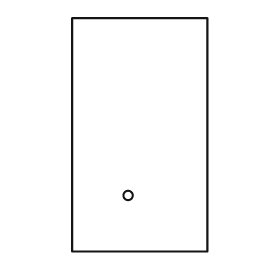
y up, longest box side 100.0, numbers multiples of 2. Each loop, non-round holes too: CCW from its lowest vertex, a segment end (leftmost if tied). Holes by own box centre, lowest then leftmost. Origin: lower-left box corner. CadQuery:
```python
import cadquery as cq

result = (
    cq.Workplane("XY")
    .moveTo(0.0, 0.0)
    .lineTo(58.0, 0.0)
    .lineTo(58.0, 100.0)
    .lineTo(0.0, 100.0)
    .close()
    .moveTo(24.0, 24.0)
    .circle(2.0)
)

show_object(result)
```